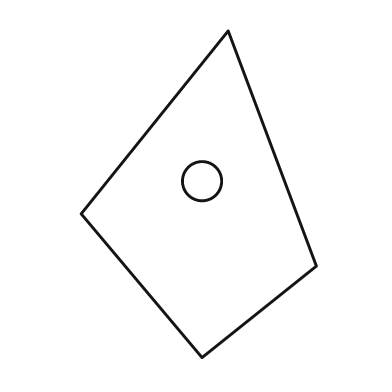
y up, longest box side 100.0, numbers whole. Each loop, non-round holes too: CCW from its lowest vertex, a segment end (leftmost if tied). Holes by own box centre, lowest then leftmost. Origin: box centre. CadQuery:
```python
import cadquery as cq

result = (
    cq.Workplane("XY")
    .moveTo(1.0, -50.0)
    .lineTo(36.0, -22.0)
    .lineTo(9.0, 50.0)
    .lineTo(-36.0, -6.0)
    .close()
    .moveTo(1.0, 4.0)
    .circle(6.0)
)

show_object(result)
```